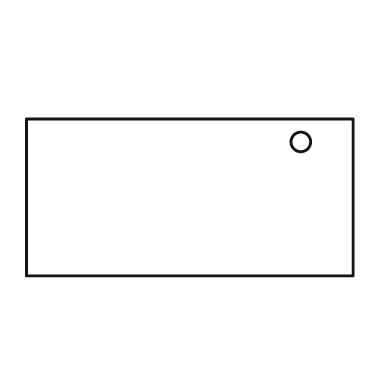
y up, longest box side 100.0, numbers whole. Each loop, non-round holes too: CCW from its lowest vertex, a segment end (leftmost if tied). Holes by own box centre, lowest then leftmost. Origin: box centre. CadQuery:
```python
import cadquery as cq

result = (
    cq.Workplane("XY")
    .moveTo(-50.0, -24.0)
    .lineTo(50.0, -24.0)
    .lineTo(50.0, 24.0)
    .lineTo(-50.0, 24.0)
    .close()
    .moveTo(34.0, 17.0)
    .circle(3.0)
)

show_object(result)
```